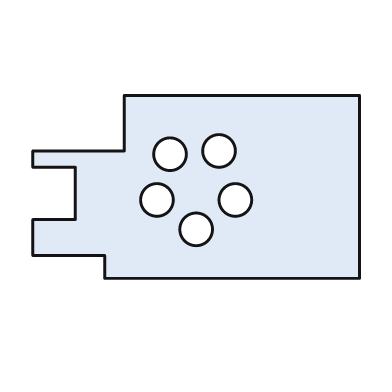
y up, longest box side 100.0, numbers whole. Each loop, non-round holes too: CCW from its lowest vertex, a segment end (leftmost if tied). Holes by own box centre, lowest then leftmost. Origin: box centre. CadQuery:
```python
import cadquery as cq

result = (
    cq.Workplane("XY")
    .moveTo(-28.0, -28.0)
    .lineTo(50.0, -28.0)
    .lineTo(50.0, 28.0)
    .lineTo(-22.0, 28.0)
    .lineTo(-22.0, 11.0)
    .lineTo(-50.0, 11.0)
    .lineTo(-50.0, 6.0)
    .lineTo(-37.0, 6.0)
    .lineTo(-37.0, -10.0)
    .lineTo(-50.0, -10.0)
    .lineTo(-50.0, -21.0)
    .lineTo(-28.0, -21.0)
    .close()
    .moveTo(0.0, -13.0)
    .circle(5.0)
    .moveTo(-12.0, -4.0)
    .circle(5.0)
    .moveTo(12.0, -4.0)
    .circle(5.0)
    .moveTo(-8.0, 10.0)
    .circle(5.0)
    .moveTo(7.0, 11.0)
    .circle(5.0)
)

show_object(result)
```